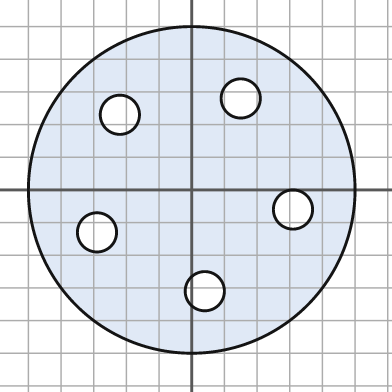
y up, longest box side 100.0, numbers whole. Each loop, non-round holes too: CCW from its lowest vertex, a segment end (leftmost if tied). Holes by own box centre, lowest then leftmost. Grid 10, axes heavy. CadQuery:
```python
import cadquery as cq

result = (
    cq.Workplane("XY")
    .moveTo(0.0, 0.0)
    .circle(50.0)
    .moveTo(4.0, -31.0)
    .circle(6.0)
    .moveTo(-29.0, -13.0)
    .circle(6.0)
    .moveTo(31.0, -6.0)
    .circle(6.0)
    .moveTo(-22.0, 23.0)
    .circle(6.0)
    .moveTo(15.0, 28.0)
    .circle(6.0)
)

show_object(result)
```